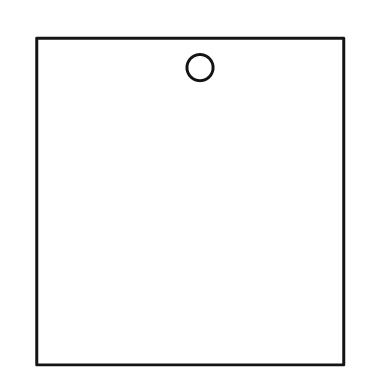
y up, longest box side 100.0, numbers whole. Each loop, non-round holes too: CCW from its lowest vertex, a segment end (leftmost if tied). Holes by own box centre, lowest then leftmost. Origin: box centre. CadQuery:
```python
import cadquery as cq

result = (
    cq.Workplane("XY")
    .moveTo(-47.0, -50.0)
    .lineTo(47.0, -50.0)
    .lineTo(47.0, 50.0)
    .lineTo(-47.0, 50.0)
    .close()
    .moveTo(3.0, 41.0)
    .circle(4.0)
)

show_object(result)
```